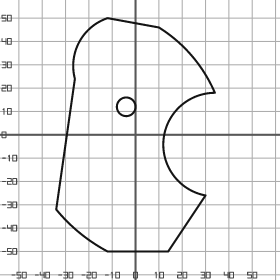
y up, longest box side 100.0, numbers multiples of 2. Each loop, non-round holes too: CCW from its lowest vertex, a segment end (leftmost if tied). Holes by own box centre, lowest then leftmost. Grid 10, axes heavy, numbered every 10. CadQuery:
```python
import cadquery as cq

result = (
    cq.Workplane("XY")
    .moveTo(-12.0, -50.0)
    .lineTo(14.0, -50.0)
    .lineTo(30.0, -26.0)
    .threePointArc((12.0, -2.0), (34.0, 18.0))
    .threePointArc((24.0, 34.0), (10.0, 46.0))
    .lineTo(-12.0, 50.0)
    .threePointArc((-24.0, 40.0), (-26.0, 24.0))
    .lineTo(-34.0, -32.0)
    .threePointArc((-24.0, -42.0), (-12.0, -50.0))
    .close()
    .moveTo(-4.0, 12.0)
    .circle(4.0)
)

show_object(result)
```